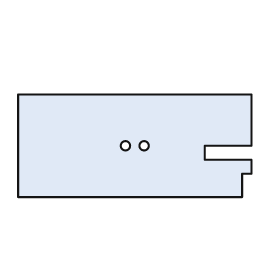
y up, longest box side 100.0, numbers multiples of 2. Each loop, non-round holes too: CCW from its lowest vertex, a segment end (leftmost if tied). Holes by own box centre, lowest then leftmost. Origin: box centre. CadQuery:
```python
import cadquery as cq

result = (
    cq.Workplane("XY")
    .moveTo(-50.0, -22.0)
    .lineTo(46.0, -22.0)
    .lineTo(46.0, -12.0)
    .lineTo(50.0, -12.0)
    .lineTo(50.0, -6.0)
    .lineTo(30.0, -6.0)
    .lineTo(30.0, 0.0)
    .lineTo(50.0, 0.0)
    .lineTo(50.0, 22.0)
    .lineTo(-50.0, 22.0)
    .close()
    .moveTo(-4.0, 0.0)
    .circle(2.0)
    .moveTo(4.0, 0.0)
    .circle(2.0)
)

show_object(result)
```